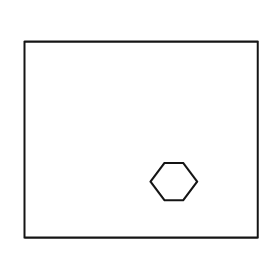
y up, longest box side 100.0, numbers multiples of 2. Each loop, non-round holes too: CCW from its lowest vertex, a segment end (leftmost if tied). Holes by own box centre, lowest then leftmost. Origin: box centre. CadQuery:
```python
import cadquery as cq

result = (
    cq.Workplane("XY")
    .moveTo(-50.0, -42.0)
    .lineTo(50.0, -42.0)
    .lineTo(50.0, 42.0)
    .lineTo(-50.0, 42.0)
    .close()
    .moveTo(10.0, -26.0)
    .lineTo(18.0, -26.0)
    .lineTo(24.0, -18.0)
    .lineTo(18.0, -10.0)
    .lineTo(10.0, -10.0)
    .lineTo(4.0, -18.0)
    .close()
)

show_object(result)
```